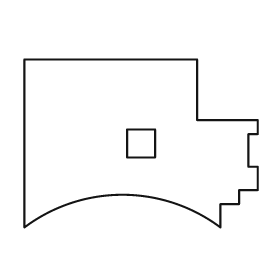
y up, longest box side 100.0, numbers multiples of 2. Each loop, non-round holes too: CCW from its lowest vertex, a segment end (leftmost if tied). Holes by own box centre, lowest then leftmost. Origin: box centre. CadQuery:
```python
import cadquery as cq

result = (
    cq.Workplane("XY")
    .moveTo(-50.0, -36.0)
    .threePointArc((-8.0, -22.0), (34.0, -36.0))
    .lineTo(34.0, -26.0)
    .lineTo(42.0, -26.0)
    .lineTo(42.0, -20.0)
    .lineTo(50.0, -20.0)
    .lineTo(50.0, -10.0)
    .lineTo(46.0, -10.0)
    .lineTo(46.0, 4.0)
    .lineTo(50.0, 4.0)
    .lineTo(50.0, 10.0)
    .lineTo(24.0, 10.0)
    .lineTo(24.0, 36.0)
    .lineTo(-50.0, 36.0)
    .close()
    .moveTo(-6.0, -6.0)
    .lineTo(6.0, -6.0)
    .lineTo(6.0, 6.0)
    .lineTo(-6.0, 6.0)
    .close()
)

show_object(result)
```